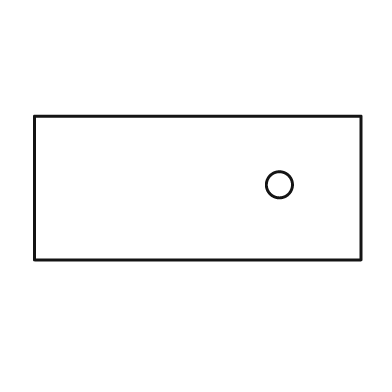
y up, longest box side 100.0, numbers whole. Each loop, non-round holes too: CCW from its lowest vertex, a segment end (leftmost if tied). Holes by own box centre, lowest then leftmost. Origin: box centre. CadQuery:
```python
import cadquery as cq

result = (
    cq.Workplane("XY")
    .moveTo(-50.0, -22.0)
    .lineTo(50.0, -22.0)
    .lineTo(50.0, 22.0)
    .lineTo(-50.0, 22.0)
    .close()
    .moveTo(25.0, 1.0)
    .circle(4.0)
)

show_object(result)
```